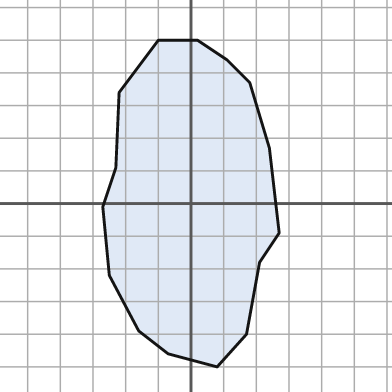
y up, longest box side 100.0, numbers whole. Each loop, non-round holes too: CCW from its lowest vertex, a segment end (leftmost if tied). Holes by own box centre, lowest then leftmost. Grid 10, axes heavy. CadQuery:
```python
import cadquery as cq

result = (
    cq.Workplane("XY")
    .moveTo(8.0, -50.0)
    .lineTo(17.0, -40.0)
    .lineTo(21.0, -18.0)
    .lineTo(27.0, -9.0)
    .lineTo(24.0, 17.0)
    .lineTo(18.0, 37.0)
    .lineTo(11.0, 44.0)
    .lineTo(2.0, 50.0)
    .lineTo(-10.0, 50.0)
    .lineTo(-22.0, 34.0)
    .lineTo(-23.0, 11.0)
    .lineTo(-27.0, -1.0)
    .lineTo(-25.0, -22.0)
    .lineTo(-16.0, -39.0)
    .lineTo(-7.0, -46.0)
    .close()
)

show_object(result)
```